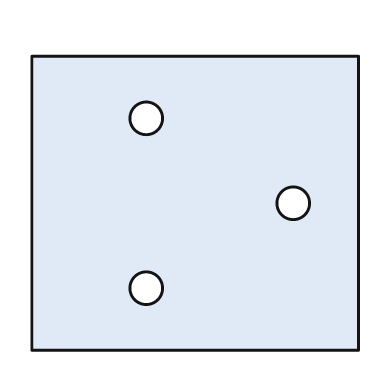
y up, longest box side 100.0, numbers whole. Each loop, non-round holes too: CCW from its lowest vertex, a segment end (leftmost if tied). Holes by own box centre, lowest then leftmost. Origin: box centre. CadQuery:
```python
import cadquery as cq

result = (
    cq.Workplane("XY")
    .moveTo(-50.0, -45.0)
    .lineTo(50.0, -45.0)
    .lineTo(50.0, 45.0)
    .lineTo(-50.0, 45.0)
    .close()
    .moveTo(-15.0, -26.0)
    .circle(5.0)
    .moveTo(30.0, 0.0)
    .circle(5.0)
    .moveTo(-15.0, 26.0)
    .circle(5.0)
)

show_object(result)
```